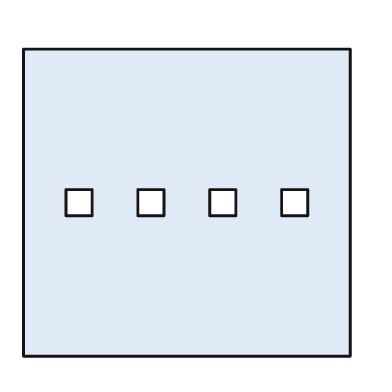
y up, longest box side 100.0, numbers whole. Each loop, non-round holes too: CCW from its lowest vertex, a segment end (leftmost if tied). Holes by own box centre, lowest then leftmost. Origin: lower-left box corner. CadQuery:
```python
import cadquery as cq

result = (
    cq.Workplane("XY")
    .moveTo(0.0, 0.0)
    .lineTo(100.0, 0.0)
    .lineTo(100.0, 94.0)
    .lineTo(0.0, 94.0)
    .close()
    .moveTo(13.0, 43.0)
    .lineTo(21.0, 43.0)
    .lineTo(21.0, 51.0)
    .lineTo(13.0, 51.0)
    .close()
    .moveTo(35.0, 43.0)
    .lineTo(43.0, 43.0)
    .lineTo(43.0, 51.0)
    .lineTo(35.0, 51.0)
    .close()
    .moveTo(57.0, 43.0)
    .lineTo(65.0, 43.0)
    .lineTo(65.0, 51.0)
    .lineTo(57.0, 51.0)
    .close()
    .moveTo(79.0, 43.0)
    .lineTo(87.0, 43.0)
    .lineTo(87.0, 51.0)
    .lineTo(79.0, 51.0)
    .close()
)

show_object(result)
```